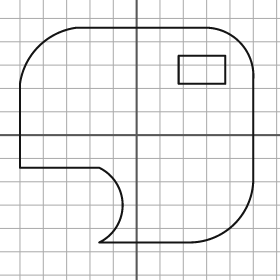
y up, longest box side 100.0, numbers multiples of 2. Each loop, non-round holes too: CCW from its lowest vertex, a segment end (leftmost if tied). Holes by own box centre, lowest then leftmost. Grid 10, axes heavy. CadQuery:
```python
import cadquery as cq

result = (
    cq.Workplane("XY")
    .moveTo(-16.0, -46.0)
    .lineTo(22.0, -46.0)
    .threePointArc((42.0, -38.0), (50.0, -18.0))
    .lineTo(50.0, 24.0)
    .threePointArc((44.0, 40.0), (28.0, 46.0))
    .lineTo(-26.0, 46.0)
    .threePointArc((-42.0, 38.0), (-50.0, 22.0))
    .lineTo(-50.0, -14.0)
    .lineTo(-16.0, -14.0)
    .threePointArc((-6.0, -30.0), (-16.0, -46.0))
    .close()
    .moveTo(18.0, 22.0)
    .lineTo(38.0, 22.0)
    .lineTo(38.0, 34.0)
    .lineTo(18.0, 34.0)
    .close()
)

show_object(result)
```